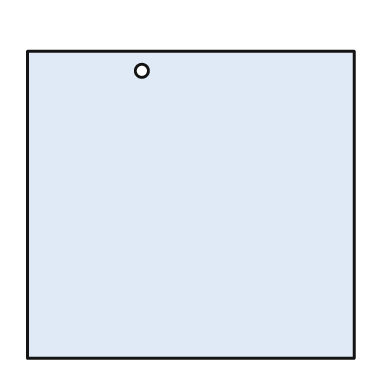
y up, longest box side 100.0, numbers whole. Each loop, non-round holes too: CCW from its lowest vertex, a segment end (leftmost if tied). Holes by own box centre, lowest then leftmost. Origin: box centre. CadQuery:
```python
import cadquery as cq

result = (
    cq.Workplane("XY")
    .moveTo(-50.0, -47.0)
    .lineTo(50.0, -47.0)
    .lineTo(50.0, 47.0)
    .lineTo(-50.0, 47.0)
    .close()
    .moveTo(-15.0, 41.0)
    .circle(2.0)
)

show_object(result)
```